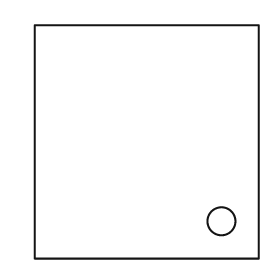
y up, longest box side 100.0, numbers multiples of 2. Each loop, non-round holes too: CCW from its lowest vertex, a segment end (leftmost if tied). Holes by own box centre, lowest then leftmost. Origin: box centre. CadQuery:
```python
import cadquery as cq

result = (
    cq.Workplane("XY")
    .moveTo(-48.0, -50.0)
    .lineTo(48.0, -50.0)
    .lineTo(48.0, 50.0)
    .lineTo(-48.0, 50.0)
    .close()
    .moveTo(32.0, -34.0)
    .circle(6.0)
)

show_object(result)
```